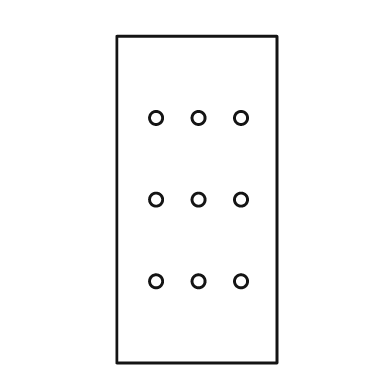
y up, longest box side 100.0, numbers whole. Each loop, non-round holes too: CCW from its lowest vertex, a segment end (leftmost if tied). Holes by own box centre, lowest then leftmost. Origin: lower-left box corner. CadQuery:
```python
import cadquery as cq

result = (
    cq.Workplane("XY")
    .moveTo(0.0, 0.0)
    .lineTo(49.0, 0.0)
    .lineTo(49.0, 100.0)
    .lineTo(0.0, 100.0)
    .close()
    .moveTo(12.0, 25.0)
    .circle(2.0)
    .moveTo(25.0, 25.0)
    .circle(2.0)
    .moveTo(38.0, 25.0)
    .circle(2.0)
    .moveTo(12.0, 50.0)
    .circle(2.0)
    .moveTo(25.0, 50.0)
    .circle(2.0)
    .moveTo(38.0, 50.0)
    .circle(2.0)
    .moveTo(12.0, 75.0)
    .circle(2.0)
    .moveTo(25.0, 75.0)
    .circle(2.0)
    .moveTo(38.0, 75.0)
    .circle(2.0)
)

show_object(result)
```